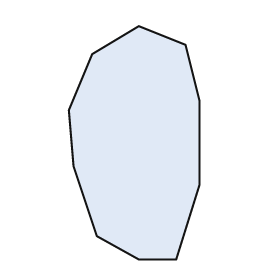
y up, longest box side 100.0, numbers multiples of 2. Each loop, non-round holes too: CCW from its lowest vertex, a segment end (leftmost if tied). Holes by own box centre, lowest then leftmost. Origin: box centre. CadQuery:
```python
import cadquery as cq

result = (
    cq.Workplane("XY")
    .moveTo(2.0, -50.0)
    .lineTo(18.0, -50.0)
    .lineTo(28.0, -18.0)
    .lineTo(28.0, 18.0)
    .lineTo(22.0, 42.0)
    .lineTo(2.0, 50.0)
    .lineTo(-18.0, 38.0)
    .lineTo(-28.0, 14.0)
    .lineTo(-26.0, -10.0)
    .lineTo(-16.0, -40.0)
    .close()
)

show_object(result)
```